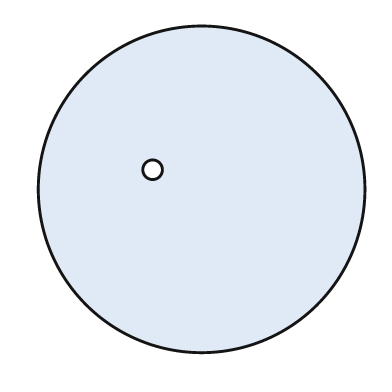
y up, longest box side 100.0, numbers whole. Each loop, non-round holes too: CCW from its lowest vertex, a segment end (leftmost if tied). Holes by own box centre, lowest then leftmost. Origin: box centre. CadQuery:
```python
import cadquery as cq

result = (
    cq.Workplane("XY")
    .moveTo(0.0, 0.0)
    .circle(50.0)
    .moveTo(-15.0, 6.0)
    .circle(3.0)
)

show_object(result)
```